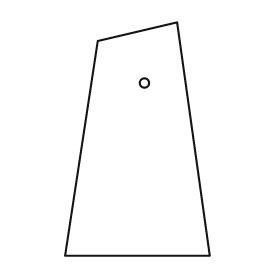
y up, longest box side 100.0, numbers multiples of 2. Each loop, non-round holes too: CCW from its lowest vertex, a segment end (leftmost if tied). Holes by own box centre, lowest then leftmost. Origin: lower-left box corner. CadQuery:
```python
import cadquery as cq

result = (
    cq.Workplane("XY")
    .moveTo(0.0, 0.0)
    .lineTo(62.0, 0.0)
    .lineTo(48.0, 100.0)
    .lineTo(14.0, 92.0)
    .close()
    .moveTo(34.0, 74.0)
    .circle(2.0)
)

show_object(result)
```